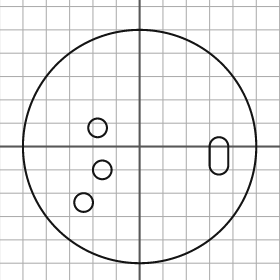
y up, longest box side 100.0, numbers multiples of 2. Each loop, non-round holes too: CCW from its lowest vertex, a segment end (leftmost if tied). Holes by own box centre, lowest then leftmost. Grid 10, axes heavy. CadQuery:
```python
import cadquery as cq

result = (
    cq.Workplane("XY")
    .moveTo(0.0, 0.0)
    .circle(50.0)
    .moveTo(-24.0, -24.0)
    .circle(4.0)
    .moveTo(-16.0, -10.0)
    .circle(4.0)
    .moveTo(30.0, -8.0)
    .threePointArc((34.0, -12.0), (38.0, -8.0))
    .lineTo(38.0, 0.0)
    .threePointArc((34.0, 4.0), (30.0, 0.0))
    .close()
    .moveTo(-18.0, 8.0)
    .circle(4.0)
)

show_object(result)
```